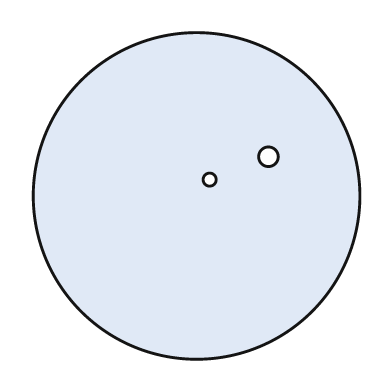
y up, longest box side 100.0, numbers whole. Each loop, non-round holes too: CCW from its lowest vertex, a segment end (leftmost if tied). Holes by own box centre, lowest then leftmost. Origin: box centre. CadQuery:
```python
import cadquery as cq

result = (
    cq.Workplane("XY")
    .moveTo(0.0, 0.0)
    .circle(50.0)
    .moveTo(4.0, 5.0)
    .circle(2.0)
    .moveTo(22.0, 12.0)
    .circle(3.0)
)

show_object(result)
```